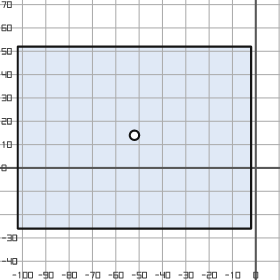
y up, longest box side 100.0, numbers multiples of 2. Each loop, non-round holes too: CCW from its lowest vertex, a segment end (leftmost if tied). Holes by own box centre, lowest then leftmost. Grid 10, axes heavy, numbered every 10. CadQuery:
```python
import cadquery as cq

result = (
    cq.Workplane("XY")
    .moveTo(-102.0, -26.0)
    .lineTo(-2.0, -26.0)
    .lineTo(-2.0, 52.0)
    .lineTo(-102.0, 52.0)
    .close()
    .moveTo(-52.0, 14.0)
    .circle(2.0)
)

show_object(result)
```